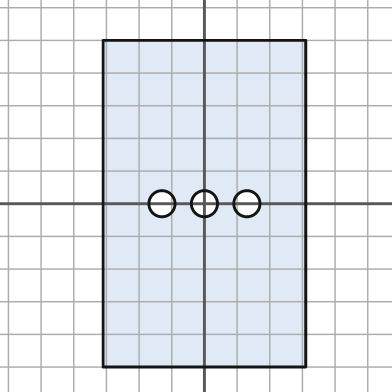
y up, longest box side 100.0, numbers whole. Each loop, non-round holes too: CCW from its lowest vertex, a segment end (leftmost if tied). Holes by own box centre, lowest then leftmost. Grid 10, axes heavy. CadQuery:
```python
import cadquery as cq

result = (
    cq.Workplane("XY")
    .moveTo(-31.0, -50.0)
    .lineTo(31.0, -50.0)
    .lineTo(31.0, 50.0)
    .lineTo(-31.0, 50.0)
    .close()
    .moveTo(-13.0, 0.0)
    .circle(4.0)
    .moveTo(0.0, 0.0)
    .circle(4.0)
    .moveTo(13.0, 0.0)
    .circle(4.0)
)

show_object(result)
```